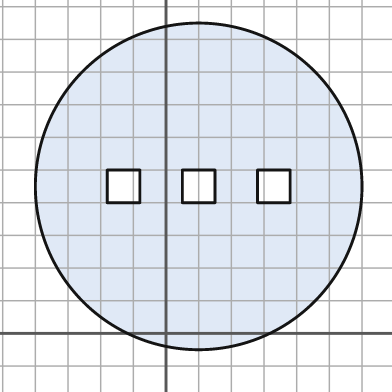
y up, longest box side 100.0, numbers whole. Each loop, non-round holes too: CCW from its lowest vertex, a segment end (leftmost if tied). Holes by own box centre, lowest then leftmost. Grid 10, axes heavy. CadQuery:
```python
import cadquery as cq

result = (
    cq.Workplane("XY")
    .moveTo(10.0, 45.0)
    .circle(50.0)
    .moveTo(-18.0, 40.0)
    .lineTo(-8.0, 40.0)
    .lineTo(-8.0, 50.0)
    .lineTo(-18.0, 50.0)
    .close()
    .moveTo(5.0, 40.0)
    .lineTo(15.0, 40.0)
    .lineTo(15.0, 50.0)
    .lineTo(5.0, 50.0)
    .close()
    .moveTo(28.0, 40.0)
    .lineTo(38.0, 40.0)
    .lineTo(38.0, 50.0)
    .lineTo(28.0, 50.0)
    .close()
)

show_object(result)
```